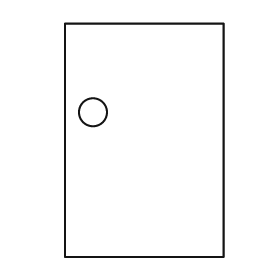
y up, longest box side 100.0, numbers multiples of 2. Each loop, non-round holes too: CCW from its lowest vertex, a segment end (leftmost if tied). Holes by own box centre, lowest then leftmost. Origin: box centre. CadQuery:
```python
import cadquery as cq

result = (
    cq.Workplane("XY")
    .moveTo(-34.0, -50.0)
    .lineTo(34.0, -50.0)
    .lineTo(34.0, 50.0)
    .lineTo(-34.0, 50.0)
    .close()
    .moveTo(-22.0, 12.0)
    .circle(6.0)
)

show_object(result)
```